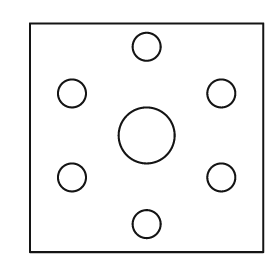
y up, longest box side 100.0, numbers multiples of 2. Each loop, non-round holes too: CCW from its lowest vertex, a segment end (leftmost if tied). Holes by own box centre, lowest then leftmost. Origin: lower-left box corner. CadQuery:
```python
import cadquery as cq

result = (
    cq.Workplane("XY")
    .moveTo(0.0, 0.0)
    .lineTo(100.0, 0.0)
    .lineTo(100.0, 98.0)
    .lineTo(0.0, 98.0)
    .close()
    .moveTo(50.0, 12.0)
    .circle(6.0)
    .moveTo(18.0, 32.0)
    .circle(6.0)
    .moveTo(82.0, 32.0)
    .circle(6.0)
    .moveTo(50.0, 50.0)
    .circle(12.0)
    .moveTo(18.0, 68.0)
    .circle(6.0)
    .moveTo(82.0, 68.0)
    .circle(6.0)
    .moveTo(50.0, 88.0)
    .circle(6.0)
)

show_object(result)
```